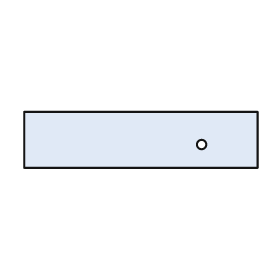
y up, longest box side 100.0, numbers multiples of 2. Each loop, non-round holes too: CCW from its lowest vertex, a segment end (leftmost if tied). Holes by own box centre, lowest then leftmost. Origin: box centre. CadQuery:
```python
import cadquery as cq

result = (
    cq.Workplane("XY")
    .moveTo(-50.0, -12.0)
    .lineTo(50.0, -12.0)
    .lineTo(50.0, 12.0)
    .lineTo(-50.0, 12.0)
    .close()
    .moveTo(26.0, -2.0)
    .circle(2.0)
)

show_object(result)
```